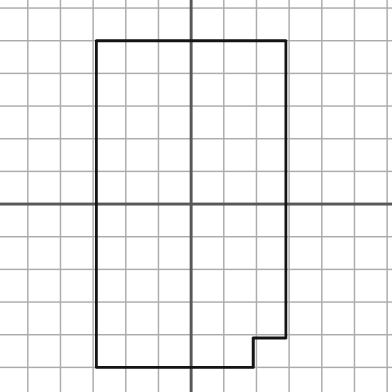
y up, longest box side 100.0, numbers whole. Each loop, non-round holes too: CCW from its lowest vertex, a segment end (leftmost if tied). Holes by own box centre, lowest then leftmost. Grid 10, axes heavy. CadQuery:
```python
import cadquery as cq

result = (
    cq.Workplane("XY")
    .moveTo(-29.0, -50.0)
    .lineTo(19.0, -50.0)
    .lineTo(19.0, -41.0)
    .lineTo(29.0, -41.0)
    .lineTo(29.0, 50.0)
    .lineTo(-29.0, 50.0)
    .close()
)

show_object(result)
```